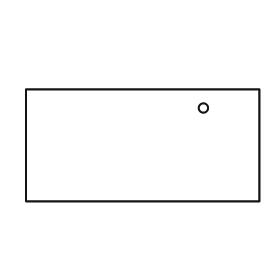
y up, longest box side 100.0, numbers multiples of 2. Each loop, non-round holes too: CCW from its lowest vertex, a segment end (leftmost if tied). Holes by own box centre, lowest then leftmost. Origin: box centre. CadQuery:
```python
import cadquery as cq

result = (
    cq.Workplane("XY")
    .moveTo(-50.0, -24.0)
    .lineTo(50.0, -24.0)
    .lineTo(50.0, 24.0)
    .lineTo(-50.0, 24.0)
    .close()
    .moveTo(26.0, 16.0)
    .circle(2.0)
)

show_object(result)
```